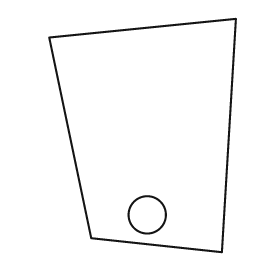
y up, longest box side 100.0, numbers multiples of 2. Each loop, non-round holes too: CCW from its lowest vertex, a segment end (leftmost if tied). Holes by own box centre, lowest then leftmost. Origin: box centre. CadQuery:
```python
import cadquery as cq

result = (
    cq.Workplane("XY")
    .moveTo(34.0, -50.0)
    .lineTo(40.0, 50.0)
    .lineTo(-40.0, 42.0)
    .lineTo(-22.0, -44.0)
    .close()
    .moveTo(2.0, -34.0)
    .circle(8.0)
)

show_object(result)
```